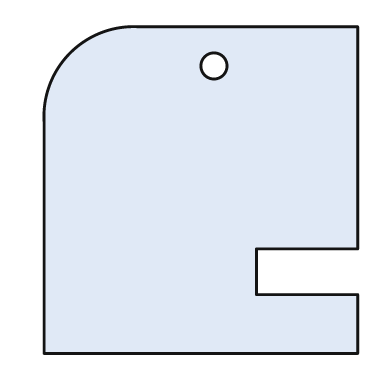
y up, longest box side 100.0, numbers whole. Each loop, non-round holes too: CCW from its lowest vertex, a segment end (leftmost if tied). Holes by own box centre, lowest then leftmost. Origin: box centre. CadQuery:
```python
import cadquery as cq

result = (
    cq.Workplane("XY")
    .moveTo(-48.0, -50.0)
    .lineTo(48.0, -50.0)
    .lineTo(48.0, -32.0)
    .lineTo(17.0, -32.0)
    .lineTo(17.0, -18.0)
    .lineTo(48.0, -18.0)
    .lineTo(48.0, 50.0)
    .lineTo(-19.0, 50.0)
    .threePointArc((-40.0, 42.0), (-48.0, 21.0))
    .close()
    .moveTo(4.0, 38.0)
    .circle(4.0)
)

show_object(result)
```